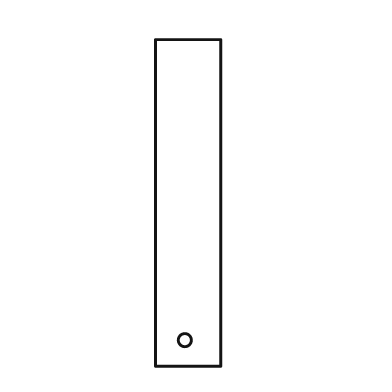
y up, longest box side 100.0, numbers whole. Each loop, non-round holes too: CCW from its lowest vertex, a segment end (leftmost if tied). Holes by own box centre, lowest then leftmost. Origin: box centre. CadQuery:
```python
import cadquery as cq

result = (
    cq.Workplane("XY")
    .moveTo(-10.0, -50.0)
    .lineTo(10.0, -50.0)
    .lineTo(10.0, 50.0)
    .lineTo(-10.0, 50.0)
    .close()
    .moveTo(-1.0, -42.0)
    .circle(2.0)
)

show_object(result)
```